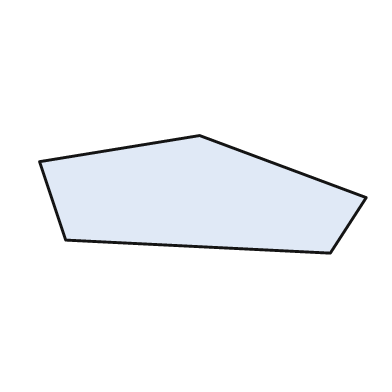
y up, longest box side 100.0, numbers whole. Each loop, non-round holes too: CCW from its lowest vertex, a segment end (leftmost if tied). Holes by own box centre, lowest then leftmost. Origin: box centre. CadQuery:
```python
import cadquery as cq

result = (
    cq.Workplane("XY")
    .moveTo(39.0, -18.0)
    .lineTo(50.0, -1.0)
    .lineTo(-1.0, 18.0)
    .lineTo(-50.0, 10.0)
    .lineTo(-42.0, -14.0)
    .close()
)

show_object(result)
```